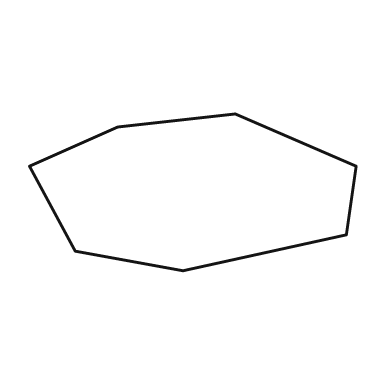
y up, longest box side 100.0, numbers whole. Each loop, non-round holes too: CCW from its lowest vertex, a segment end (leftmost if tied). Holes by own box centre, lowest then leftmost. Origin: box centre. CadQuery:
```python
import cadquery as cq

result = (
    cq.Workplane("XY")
    .moveTo(-3.0, -24.0)
    .lineTo(47.0, -13.0)
    .lineTo(50.0, 8.0)
    .lineTo(13.0, 24.0)
    .lineTo(-23.0, 20.0)
    .lineTo(-50.0, 8.0)
    .lineTo(-36.0, -18.0)
    .close()
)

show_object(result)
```